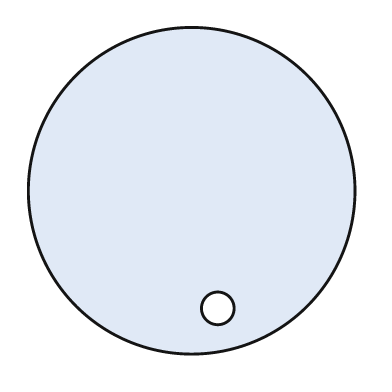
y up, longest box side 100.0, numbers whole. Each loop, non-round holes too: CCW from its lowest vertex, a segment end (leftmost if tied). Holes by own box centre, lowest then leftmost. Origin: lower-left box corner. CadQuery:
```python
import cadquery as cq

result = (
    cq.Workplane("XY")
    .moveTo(50.0, 50.0)
    .circle(50.0)
    .moveTo(58.0, 14.0)
    .circle(5.0)
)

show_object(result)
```